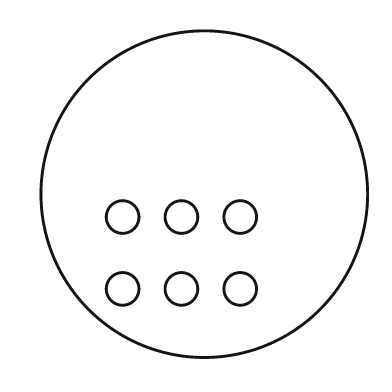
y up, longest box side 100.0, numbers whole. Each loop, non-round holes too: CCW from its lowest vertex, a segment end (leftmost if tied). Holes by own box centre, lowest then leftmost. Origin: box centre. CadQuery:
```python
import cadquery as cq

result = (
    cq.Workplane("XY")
    .moveTo(0.0, 0.0)
    .circle(50.0)
    .moveTo(-25.0, -29.0)
    .circle(5.0)
    .moveTo(-7.0, -29.0)
    .circle(5.0)
    .moveTo(11.0, -29.0)
    .circle(5.0)
    .moveTo(-25.0, -7.0)
    .circle(5.0)
    .moveTo(-7.0, -7.0)
    .circle(5.0)
    .moveTo(11.0, -7.0)
    .circle(5.0)
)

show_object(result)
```